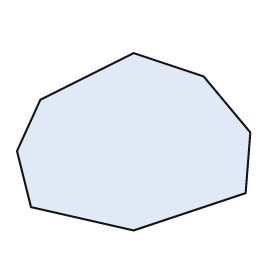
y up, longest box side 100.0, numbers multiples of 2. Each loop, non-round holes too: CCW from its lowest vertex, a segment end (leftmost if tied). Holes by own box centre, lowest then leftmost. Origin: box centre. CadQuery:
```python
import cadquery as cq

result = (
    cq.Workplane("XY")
    .moveTo(0.0, -38.0)
    .lineTo(48.0, -22.0)
    .lineTo(50.0, 4.0)
    .lineTo(30.0, 28.0)
    .lineTo(0.0, 38.0)
    .lineTo(-40.0, 18.0)
    .lineTo(-50.0, -4.0)
    .lineTo(-44.0, -28.0)
    .close()
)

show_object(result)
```